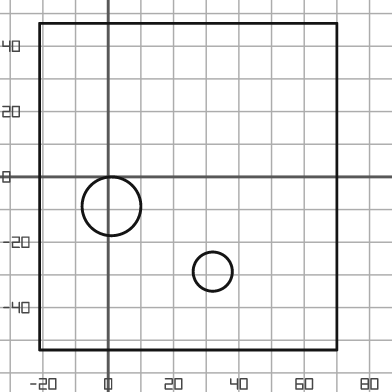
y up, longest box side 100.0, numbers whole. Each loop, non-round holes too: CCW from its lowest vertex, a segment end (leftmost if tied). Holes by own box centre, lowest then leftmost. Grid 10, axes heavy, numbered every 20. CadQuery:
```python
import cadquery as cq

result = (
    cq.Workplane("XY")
    .moveTo(-21.0, -53.0)
    .lineTo(70.0, -53.0)
    .lineTo(70.0, 47.0)
    .lineTo(-21.0, 47.0)
    .close()
    .moveTo(32.0, -29.0)
    .circle(6.0)
    .moveTo(1.0, -9.0)
    .circle(9.0)
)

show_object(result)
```